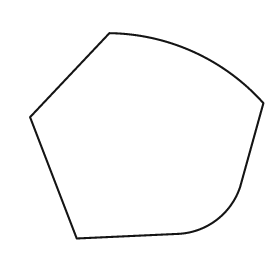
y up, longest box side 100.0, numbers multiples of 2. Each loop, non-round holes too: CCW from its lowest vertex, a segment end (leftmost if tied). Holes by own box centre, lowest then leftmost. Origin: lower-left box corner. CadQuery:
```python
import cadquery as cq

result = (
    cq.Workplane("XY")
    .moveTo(20.0, 0.0)
    .lineTo(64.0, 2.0)
    .threePointArc((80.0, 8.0), (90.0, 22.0))
    .lineTo(100.0, 58.0)
    .threePointArc((70.0, 80.0), (34.0, 88.0))
    .lineTo(0.0, 52.0)
    .close()
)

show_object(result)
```